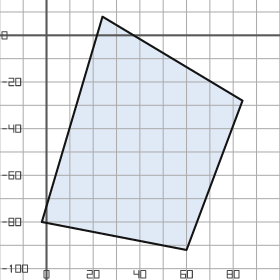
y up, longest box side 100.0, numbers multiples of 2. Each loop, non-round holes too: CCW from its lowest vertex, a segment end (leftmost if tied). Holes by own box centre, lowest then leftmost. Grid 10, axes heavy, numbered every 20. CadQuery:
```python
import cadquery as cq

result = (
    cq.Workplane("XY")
    .moveTo(60.0, -92.0)
    .lineTo(84.0, -28.0)
    .lineTo(24.0, 8.0)
    .lineTo(-2.0, -80.0)
    .close()
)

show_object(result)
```